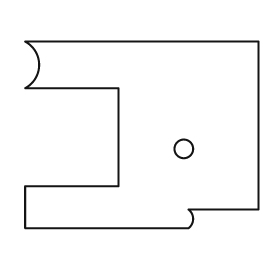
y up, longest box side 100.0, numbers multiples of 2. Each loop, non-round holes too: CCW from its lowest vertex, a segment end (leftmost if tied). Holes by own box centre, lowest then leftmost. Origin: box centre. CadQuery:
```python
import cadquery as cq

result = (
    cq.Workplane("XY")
    .moveTo(-50.0, -40.0)
    .lineTo(20.0, -40.0)
    .threePointArc((22.0, -36.0), (20.0, -32.0))
    .lineTo(50.0, -32.0)
    .lineTo(50.0, 40.0)
    .lineTo(-50.0, 40.0)
    .threePointArc((-44.0, 30.0), (-50.0, 20.0))
    .lineTo(-10.0, 20.0)
    .lineTo(-10.0, -22.0)
    .lineTo(-50.0, -22.0)
    .close()
    .moveTo(18.0, -6.0)
    .circle(4.0)
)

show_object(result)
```